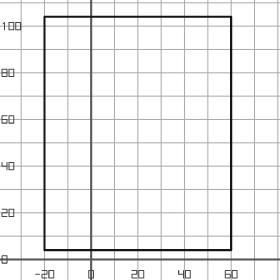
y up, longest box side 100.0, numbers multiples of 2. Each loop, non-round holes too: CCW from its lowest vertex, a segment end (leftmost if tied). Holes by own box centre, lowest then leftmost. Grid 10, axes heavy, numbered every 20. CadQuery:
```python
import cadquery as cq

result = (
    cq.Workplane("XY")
    .moveTo(-20.0, 4.0)
    .lineTo(60.0, 4.0)
    .lineTo(60.0, 104.0)
    .lineTo(-20.0, 104.0)
    .close()
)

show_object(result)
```